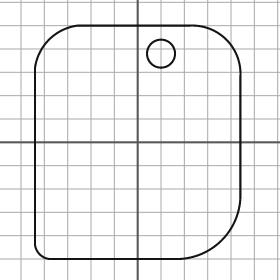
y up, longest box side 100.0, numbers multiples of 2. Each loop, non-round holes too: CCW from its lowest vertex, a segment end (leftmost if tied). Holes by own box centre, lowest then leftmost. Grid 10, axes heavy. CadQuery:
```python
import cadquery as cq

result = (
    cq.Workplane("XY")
    .moveTo(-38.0, -50.0)
    .lineTo(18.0, -50.0)
    .threePointArc((36.0, -42.0), (44.0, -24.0))
    .lineTo(44.0, 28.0)
    .threePointArc((38.0, 44.0), (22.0, 50.0))
    .lineTo(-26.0, 50.0)
    .threePointArc((-38.0, 44.0), (-44.0, 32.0))
    .lineTo(-44.0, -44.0)
    .threePointArc((-42.0, -48.0), (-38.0, -50.0))
    .close()
    .moveTo(10.0, 38.0)
    .circle(6.0)
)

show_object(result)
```